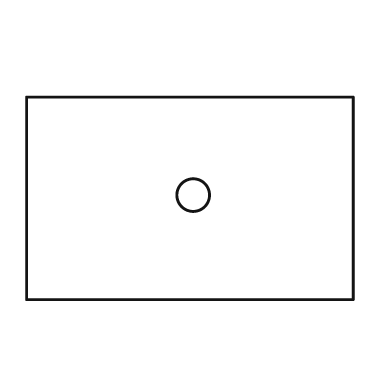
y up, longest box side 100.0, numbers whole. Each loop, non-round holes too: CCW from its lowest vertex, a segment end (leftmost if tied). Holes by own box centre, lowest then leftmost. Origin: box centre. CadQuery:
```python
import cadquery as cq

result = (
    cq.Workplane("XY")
    .moveTo(-50.0, -31.0)
    .lineTo(50.0, -31.0)
    .lineTo(50.0, 31.0)
    .lineTo(-50.0, 31.0)
    .close()
    .moveTo(1.0, 1.0)
    .circle(5.0)
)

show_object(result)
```